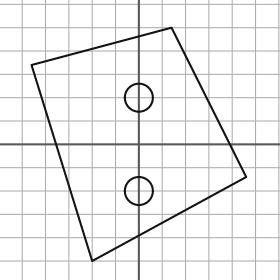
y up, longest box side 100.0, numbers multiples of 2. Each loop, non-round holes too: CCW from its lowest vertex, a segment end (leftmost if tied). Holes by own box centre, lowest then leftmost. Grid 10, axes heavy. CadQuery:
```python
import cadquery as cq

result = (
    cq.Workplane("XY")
    .moveTo(-20.0, -50.0)
    .lineTo(46.0, -14.0)
    .lineTo(14.0, 50.0)
    .lineTo(-46.0, 34.0)
    .close()
    .moveTo(0.0, -20.0)
    .circle(6.0)
    .moveTo(0.0, 20.0)
    .circle(6.0)
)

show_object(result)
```